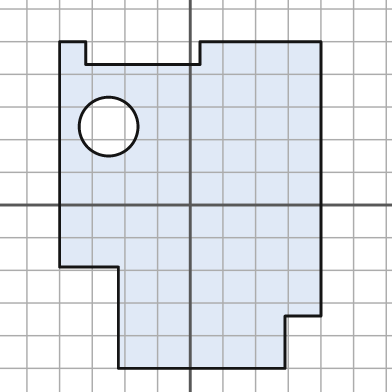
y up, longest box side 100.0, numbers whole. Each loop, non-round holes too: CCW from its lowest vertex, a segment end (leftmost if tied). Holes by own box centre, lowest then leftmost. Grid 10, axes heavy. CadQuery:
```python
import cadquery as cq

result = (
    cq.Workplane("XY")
    .moveTo(-22.0, -50.0)
    .lineTo(29.0, -50.0)
    .lineTo(29.0, -34.0)
    .lineTo(40.0, -34.0)
    .lineTo(40.0, 50.0)
    .lineTo(3.0, 50.0)
    .lineTo(3.0, 43.0)
    .lineTo(-32.0, 43.0)
    .lineTo(-32.0, 50.0)
    .lineTo(-40.0, 50.0)
    .lineTo(-40.0, -19.0)
    .lineTo(-22.0, -19.0)
    .close()
    .moveTo(-25.0, 24.0)
    .circle(9.0)
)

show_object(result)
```